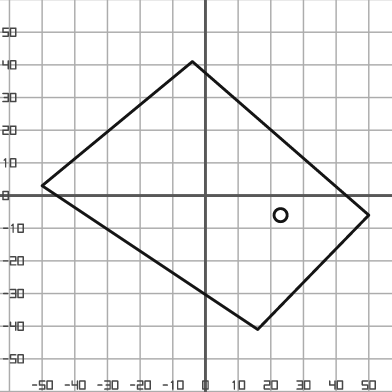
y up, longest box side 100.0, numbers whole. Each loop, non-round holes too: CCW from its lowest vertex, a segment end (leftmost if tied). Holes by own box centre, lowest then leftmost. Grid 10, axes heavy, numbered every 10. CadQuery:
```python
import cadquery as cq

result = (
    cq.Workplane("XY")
    .moveTo(16.0, -41.0)
    .lineTo(50.0, -6.0)
    .lineTo(-4.0, 41.0)
    .lineTo(-50.0, 3.0)
    .close()
    .moveTo(23.0, -6.0)
    .circle(2.0)
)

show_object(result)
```